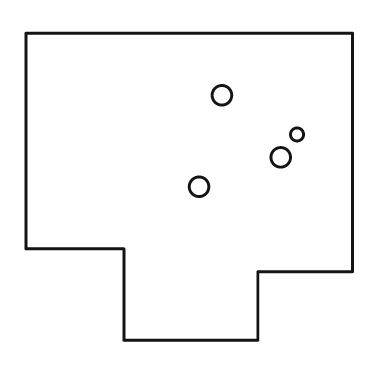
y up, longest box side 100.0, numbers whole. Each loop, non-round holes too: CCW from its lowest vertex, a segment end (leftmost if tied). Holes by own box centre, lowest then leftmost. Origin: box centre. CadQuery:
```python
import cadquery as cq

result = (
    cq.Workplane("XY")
    .moveTo(-20.0, -47.0)
    .lineTo(21.0, -47.0)
    .lineTo(21.0, -26.0)
    .lineTo(50.0, -26.0)
    .lineTo(50.0, 47.0)
    .lineTo(-50.0, 47.0)
    .lineTo(-50.0, -19.0)
    .lineTo(-20.0, -19.0)
    .close()
    .moveTo(3.0, 0.0)
    .circle(3.0)
    .moveTo(28.0, 9.0)
    .circle(3.0)
    .moveTo(33.0, 16.0)
    .circle(2.0)
    .moveTo(10.0, 28.0)
    .circle(3.0)
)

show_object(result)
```